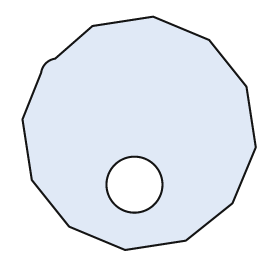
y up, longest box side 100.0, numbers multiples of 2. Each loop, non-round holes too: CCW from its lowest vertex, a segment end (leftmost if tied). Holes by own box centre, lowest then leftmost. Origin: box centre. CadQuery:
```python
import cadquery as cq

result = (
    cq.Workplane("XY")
    .moveTo(-6.0, -50.0)
    .lineTo(20.0, -46.0)
    .lineTo(40.0, -30.0)
    .lineTo(50.0, -6.0)
    .lineTo(46.0, 20.0)
    .lineTo(30.0, 40.0)
    .lineTo(6.0, 50.0)
    .lineTo(-20.0, 46.0)
    .lineTo(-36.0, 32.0)
    .threePointArc((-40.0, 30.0), (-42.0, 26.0))
    .lineTo(-50.0, 6.0)
    .lineTo(-46.0, -20.0)
    .lineTo(-30.0, -40.0)
    .close()
    .moveTo(-2.0, -22.0)
    .circle(12.0)
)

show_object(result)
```